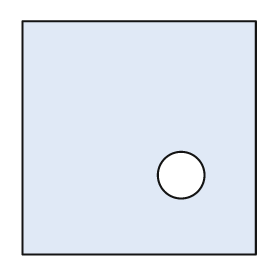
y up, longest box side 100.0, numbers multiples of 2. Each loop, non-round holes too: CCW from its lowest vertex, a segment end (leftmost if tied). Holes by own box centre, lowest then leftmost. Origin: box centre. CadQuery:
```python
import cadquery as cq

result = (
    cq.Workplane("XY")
    .moveTo(-50.0, -50.0)
    .lineTo(50.0, -50.0)
    .lineTo(50.0, 50.0)
    .lineTo(-50.0, 50.0)
    .close()
    .moveTo(18.0, -16.0)
    .circle(10.0)
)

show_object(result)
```